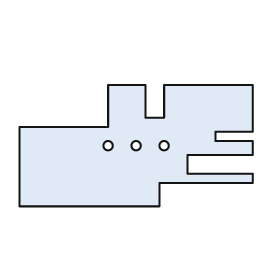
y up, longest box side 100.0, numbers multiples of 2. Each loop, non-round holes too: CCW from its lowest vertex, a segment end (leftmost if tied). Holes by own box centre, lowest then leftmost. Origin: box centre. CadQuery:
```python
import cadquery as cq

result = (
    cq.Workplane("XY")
    .moveTo(-50.0, -26.0)
    .lineTo(10.0, -26.0)
    .lineTo(10.0, -16.0)
    .lineTo(50.0, -16.0)
    .lineTo(50.0, -12.0)
    .lineTo(22.0, -12.0)
    .lineTo(22.0, -4.0)
    .lineTo(50.0, -4.0)
    .lineTo(50.0, 2.0)
    .lineTo(34.0, 2.0)
    .lineTo(34.0, 6.0)
    .lineTo(50.0, 6.0)
    .lineTo(50.0, 26.0)
    .lineTo(12.0, 26.0)
    .lineTo(12.0, 12.0)
    .lineTo(4.0, 12.0)
    .lineTo(4.0, 26.0)
    .lineTo(-12.0, 26.0)
    .lineTo(-12.0, 8.0)
    .lineTo(-50.0, 8.0)
    .close()
    .moveTo(-12.0, 0.0)
    .circle(2.0)
    .moveTo(0.0, 0.0)
    .circle(2.0)
    .moveTo(12.0, 0.0)
    .circle(2.0)
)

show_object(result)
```